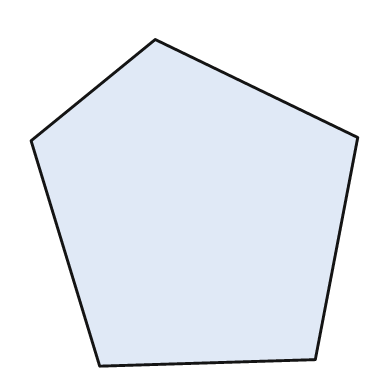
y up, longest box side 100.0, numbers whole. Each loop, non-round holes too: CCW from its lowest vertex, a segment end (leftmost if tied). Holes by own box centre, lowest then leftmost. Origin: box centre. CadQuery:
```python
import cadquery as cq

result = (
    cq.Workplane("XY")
    .moveTo(-29.0, -50.0)
    .lineTo(37.0, -48.0)
    .lineTo(50.0, 20.0)
    .lineTo(-12.0, 50.0)
    .lineTo(-50.0, 19.0)
    .close()
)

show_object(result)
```